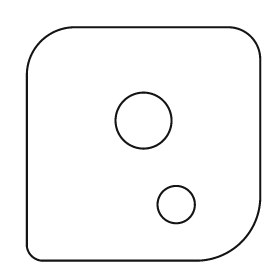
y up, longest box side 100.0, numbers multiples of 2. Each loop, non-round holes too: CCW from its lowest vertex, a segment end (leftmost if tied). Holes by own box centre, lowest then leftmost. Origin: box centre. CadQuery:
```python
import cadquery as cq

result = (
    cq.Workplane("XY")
    .moveTo(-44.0, -50.0)
    .lineTo(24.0, -50.0)
    .threePointArc((42.0, -42.0), (50.0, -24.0))
    .lineTo(50.0, 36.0)
    .threePointArc((46.0, 46.0), (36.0, 50.0))
    .lineTo(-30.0, 50.0)
    .threePointArc((-44.0, 44.0), (-50.0, 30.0))
    .lineTo(-50.0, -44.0)
    .threePointArc((-48.0, -48.0), (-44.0, -50.0))
    .close()
    .moveTo(14.0, -26.0)
    .circle(8.0)
    .moveTo(0.0, 10.0)
    .circle(12.0)
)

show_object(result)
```